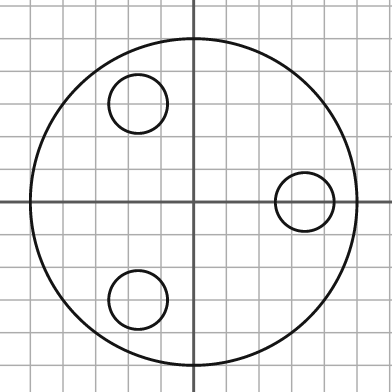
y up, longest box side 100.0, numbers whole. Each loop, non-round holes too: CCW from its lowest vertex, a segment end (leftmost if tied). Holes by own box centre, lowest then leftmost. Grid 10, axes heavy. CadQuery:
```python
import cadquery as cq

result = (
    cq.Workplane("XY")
    .moveTo(0.0, 0.0)
    .circle(50.0)
    .moveTo(-17.0, -30.0)
    .circle(9.0)
    .moveTo(34.0, 0.0)
    .circle(9.0)
    .moveTo(-17.0, 30.0)
    .circle(9.0)
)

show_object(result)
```